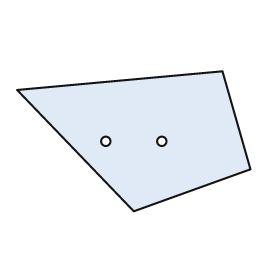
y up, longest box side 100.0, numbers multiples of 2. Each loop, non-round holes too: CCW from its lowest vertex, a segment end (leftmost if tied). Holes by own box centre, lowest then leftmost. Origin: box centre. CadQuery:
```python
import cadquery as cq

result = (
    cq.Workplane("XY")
    .moveTo(0.0, -30.0)
    .lineTo(50.0, -12.0)
    .lineTo(38.0, 30.0)
    .lineTo(-50.0, 22.0)
    .close()
    .moveTo(-12.0, 0.0)
    .circle(2.0)
    .moveTo(12.0, 0.0)
    .circle(2.0)
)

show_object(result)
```